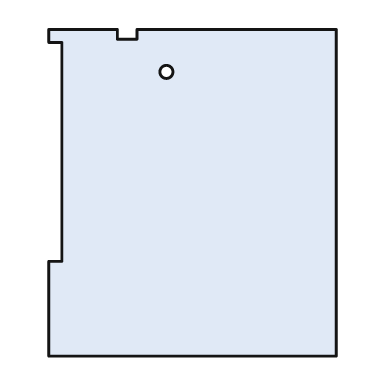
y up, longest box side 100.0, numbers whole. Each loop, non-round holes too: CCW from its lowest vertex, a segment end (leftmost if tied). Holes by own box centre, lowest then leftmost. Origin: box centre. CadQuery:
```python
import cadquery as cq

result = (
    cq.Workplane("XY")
    .moveTo(-44.0, -50.0)
    .lineTo(44.0, -50.0)
    .lineTo(44.0, 50.0)
    .lineTo(-17.0, 50.0)
    .lineTo(-17.0, 47.0)
    .lineTo(-23.0, 47.0)
    .lineTo(-23.0, 50.0)
    .lineTo(-44.0, 50.0)
    .lineTo(-44.0, 46.0)
    .lineTo(-40.0, 46.0)
    .lineTo(-40.0, -21.0)
    .lineTo(-44.0, -21.0)
    .close()
    .moveTo(-8.0, 37.0)
    .circle(2.0)
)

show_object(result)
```